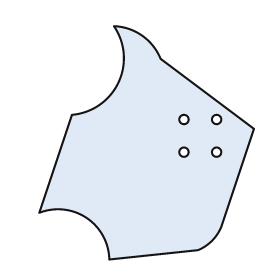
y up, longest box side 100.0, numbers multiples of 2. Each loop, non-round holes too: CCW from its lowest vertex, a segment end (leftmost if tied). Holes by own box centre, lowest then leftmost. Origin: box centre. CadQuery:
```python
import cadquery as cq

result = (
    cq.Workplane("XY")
    .moveTo(-16.0, -50.0)
    .lineTo(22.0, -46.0)
    .threePointArc((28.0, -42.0), (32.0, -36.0))
    .lineTo(46.0, 6.0)
    .lineTo(6.0, 36.0)
    .threePointArc((-2.0, 46.0), (-14.0, 50.0))
    .threePointArc((-12.0, 26.0), (-32.0, 12.0))
    .lineTo(-46.0, -30.0)
    .threePointArc((-26.0, -32.0), (-16.0, -50.0))
    .close()
    .moveTo(16.0, -4.0)
    .circle(2.0)
    .moveTo(30.0, -4.0)
    .circle(2.0)
    .moveTo(16.0, 10.0)
    .circle(2.0)
    .moveTo(30.0, 10.0)
    .circle(2.0)
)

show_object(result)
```